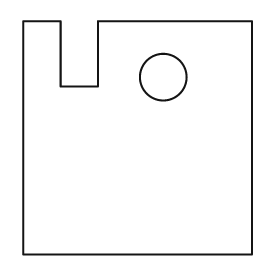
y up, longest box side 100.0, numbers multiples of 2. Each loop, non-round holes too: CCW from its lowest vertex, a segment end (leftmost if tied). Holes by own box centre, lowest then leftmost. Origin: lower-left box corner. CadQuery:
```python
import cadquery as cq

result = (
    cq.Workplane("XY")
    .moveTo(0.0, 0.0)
    .lineTo(98.0, 0.0)
    .lineTo(98.0, 100.0)
    .lineTo(32.0, 100.0)
    .lineTo(32.0, 72.0)
    .lineTo(16.0, 72.0)
    .lineTo(16.0, 100.0)
    .lineTo(0.0, 100.0)
    .close()
    .moveTo(60.0, 76.0)
    .circle(10.0)
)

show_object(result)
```